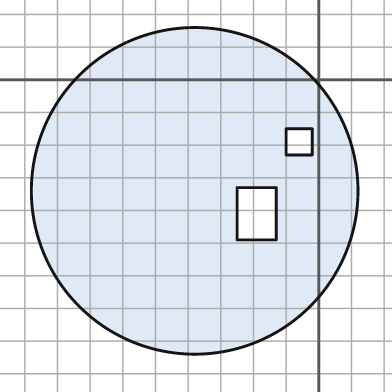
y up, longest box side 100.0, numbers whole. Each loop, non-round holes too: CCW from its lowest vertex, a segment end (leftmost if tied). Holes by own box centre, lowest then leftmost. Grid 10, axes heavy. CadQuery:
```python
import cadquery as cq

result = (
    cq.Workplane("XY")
    .moveTo(-38.0, -34.0)
    .circle(50.0)
    .moveTo(-25.0, -49.0)
    .lineTo(-13.0, -49.0)
    .lineTo(-13.0, -33.0)
    .lineTo(-25.0, -33.0)
    .close()
    .moveTo(-10.0, -23.0)
    .lineTo(-2.0, -23.0)
    .lineTo(-2.0, -15.0)
    .lineTo(-10.0, -15.0)
    .close()
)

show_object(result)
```